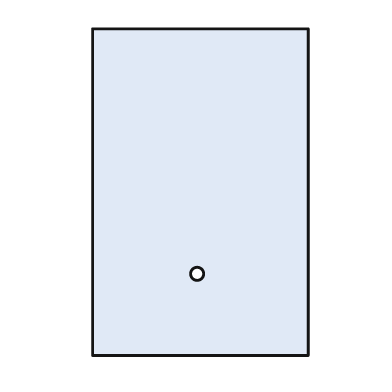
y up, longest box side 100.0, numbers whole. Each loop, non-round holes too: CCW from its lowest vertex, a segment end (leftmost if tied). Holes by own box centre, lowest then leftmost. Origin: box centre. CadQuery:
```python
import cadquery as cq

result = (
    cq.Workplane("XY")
    .moveTo(-33.0, -50.0)
    .lineTo(33.0, -50.0)
    .lineTo(33.0, 50.0)
    .lineTo(-33.0, 50.0)
    .close()
    .moveTo(-1.0, -25.0)
    .circle(2.0)
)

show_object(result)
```